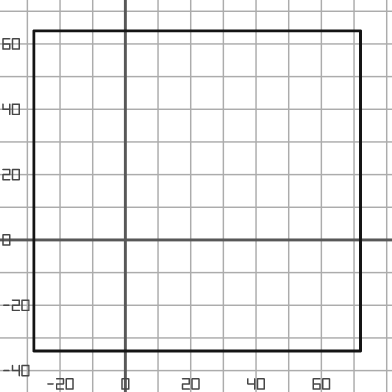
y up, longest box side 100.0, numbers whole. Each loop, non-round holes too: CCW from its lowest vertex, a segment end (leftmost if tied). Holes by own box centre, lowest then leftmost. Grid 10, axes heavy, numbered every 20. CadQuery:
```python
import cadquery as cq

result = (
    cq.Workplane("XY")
    .moveTo(-28.0, -34.0)
    .lineTo(72.0, -34.0)
    .lineTo(72.0, 64.0)
    .lineTo(-28.0, 64.0)
    .close()
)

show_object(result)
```